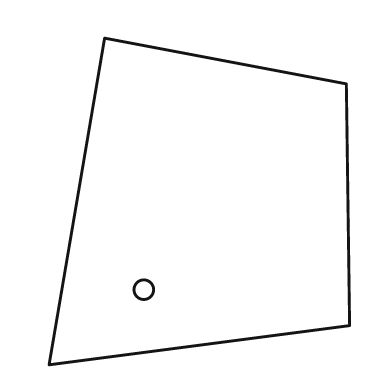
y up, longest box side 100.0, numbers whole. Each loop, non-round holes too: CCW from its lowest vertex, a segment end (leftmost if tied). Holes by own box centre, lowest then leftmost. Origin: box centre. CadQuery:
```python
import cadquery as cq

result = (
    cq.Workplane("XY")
    .moveTo(-46.0, -50.0)
    .lineTo(46.0, -38.0)
    .lineTo(45.0, 36.0)
    .lineTo(-29.0, 50.0)
    .close()
    .moveTo(-17.0, -27.0)
    .circle(3.0)
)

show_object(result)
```